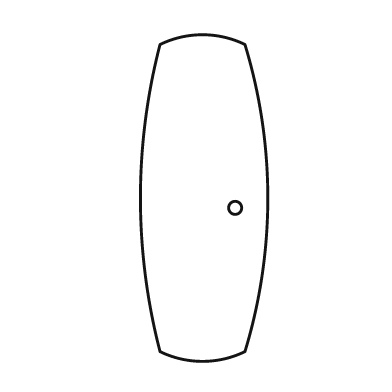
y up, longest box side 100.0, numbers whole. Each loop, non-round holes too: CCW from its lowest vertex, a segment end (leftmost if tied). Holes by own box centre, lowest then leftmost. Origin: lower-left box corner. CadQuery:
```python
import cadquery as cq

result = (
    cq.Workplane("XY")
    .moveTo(6.0, 3.0)
    .threePointArc((19.0, 0.0), (32.0, 3.0))
    .threePointArc((39.0, 50.0), (32.0, 97.0))
    .threePointArc((19.0, 100.0), (6.0, 97.0))
    .threePointArc((0.0, 50.0), (6.0, 3.0))
    .close()
    .moveTo(29.0, 47.0)
    .circle(2.0)
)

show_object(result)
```